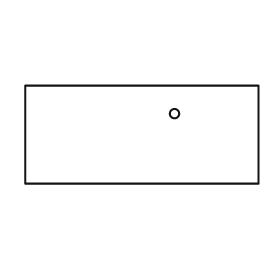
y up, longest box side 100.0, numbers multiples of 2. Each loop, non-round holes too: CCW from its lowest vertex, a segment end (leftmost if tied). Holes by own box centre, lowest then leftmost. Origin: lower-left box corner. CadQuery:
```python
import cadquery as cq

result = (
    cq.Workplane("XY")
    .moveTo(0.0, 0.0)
    .lineTo(100.0, 0.0)
    .lineTo(100.0, 42.0)
    .lineTo(0.0, 42.0)
    .close()
    .moveTo(64.0, 30.0)
    .circle(2.0)
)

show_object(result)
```